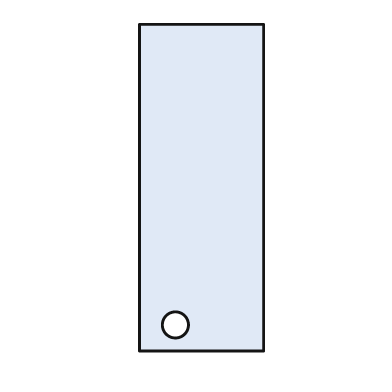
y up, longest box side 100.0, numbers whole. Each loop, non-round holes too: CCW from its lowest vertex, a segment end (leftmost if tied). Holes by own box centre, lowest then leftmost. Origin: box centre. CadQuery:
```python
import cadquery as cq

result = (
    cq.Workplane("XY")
    .moveTo(-19.0, -50.0)
    .lineTo(19.0, -50.0)
    .lineTo(19.0, 50.0)
    .lineTo(-19.0, 50.0)
    .close()
    .moveTo(-8.0, -42.0)
    .circle(4.0)
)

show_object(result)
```